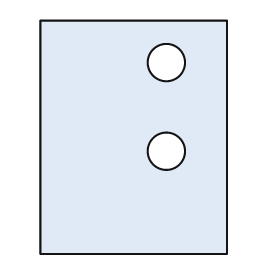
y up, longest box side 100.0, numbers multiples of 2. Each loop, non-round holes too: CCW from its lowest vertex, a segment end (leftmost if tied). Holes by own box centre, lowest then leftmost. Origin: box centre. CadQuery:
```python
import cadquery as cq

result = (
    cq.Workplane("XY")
    .moveTo(-40.0, -50.0)
    .lineTo(40.0, -50.0)
    .lineTo(40.0, 50.0)
    .lineTo(-40.0, 50.0)
    .close()
    .moveTo(14.0, -6.0)
    .circle(8.0)
    .moveTo(14.0, 32.0)
    .circle(8.0)
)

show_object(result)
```